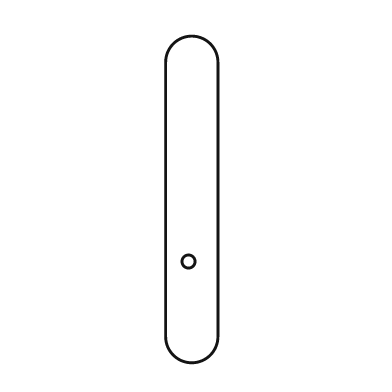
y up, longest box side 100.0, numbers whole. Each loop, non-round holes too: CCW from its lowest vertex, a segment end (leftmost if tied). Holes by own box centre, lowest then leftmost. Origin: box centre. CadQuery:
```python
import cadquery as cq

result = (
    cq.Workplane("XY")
    .moveTo(-8.0, -42.0)
    .threePointArc((0.0, -50.0), (8.0, -42.0))
    .lineTo(8.0, 42.0)
    .threePointArc((0.0, 50.0), (-8.0, 42.0))
    .close()
    .moveTo(-1.0, -19.0)
    .circle(2.0)
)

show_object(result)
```